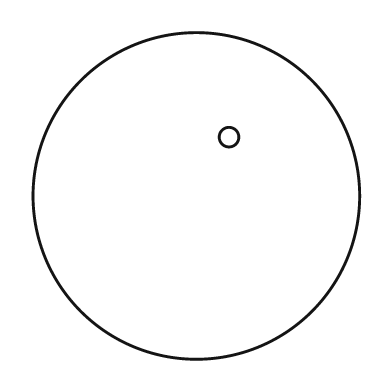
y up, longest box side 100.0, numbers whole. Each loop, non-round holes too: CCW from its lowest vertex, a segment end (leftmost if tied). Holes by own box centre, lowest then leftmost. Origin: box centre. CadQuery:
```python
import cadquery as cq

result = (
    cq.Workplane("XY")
    .moveTo(0.0, 0.0)
    .circle(50.0)
    .moveTo(10.0, 18.0)
    .circle(3.0)
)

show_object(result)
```